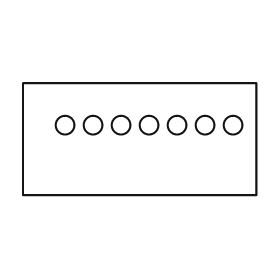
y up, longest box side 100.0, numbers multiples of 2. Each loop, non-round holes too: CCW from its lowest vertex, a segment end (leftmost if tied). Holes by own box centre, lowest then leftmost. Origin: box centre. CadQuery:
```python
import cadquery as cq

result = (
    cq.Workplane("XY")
    .moveTo(-50.0, -24.0)
    .lineTo(50.0, -24.0)
    .lineTo(50.0, 24.0)
    .lineTo(-50.0, 24.0)
    .close()
    .moveTo(-32.0, 6.0)
    .circle(4.0)
    .moveTo(-20.0, 6.0)
    .circle(4.0)
    .moveTo(-8.0, 6.0)
    .circle(4.0)
    .moveTo(4.0, 6.0)
    .circle(4.0)
    .moveTo(16.0, 6.0)
    .circle(4.0)
    .moveTo(28.0, 6.0)
    .circle(4.0)
    .moveTo(40.0, 6.0)
    .circle(4.0)
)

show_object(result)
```